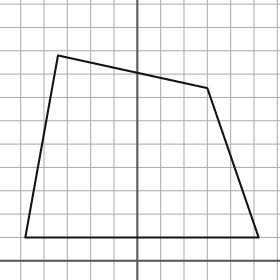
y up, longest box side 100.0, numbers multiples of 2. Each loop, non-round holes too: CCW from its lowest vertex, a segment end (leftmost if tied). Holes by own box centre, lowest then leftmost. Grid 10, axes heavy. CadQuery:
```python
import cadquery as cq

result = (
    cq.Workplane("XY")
    .moveTo(-48.0, 10.0)
    .lineTo(52.0, 10.0)
    .lineTo(30.0, 74.0)
    .lineTo(-34.0, 88.0)
    .close()
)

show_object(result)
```